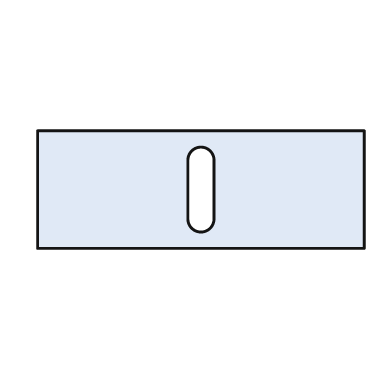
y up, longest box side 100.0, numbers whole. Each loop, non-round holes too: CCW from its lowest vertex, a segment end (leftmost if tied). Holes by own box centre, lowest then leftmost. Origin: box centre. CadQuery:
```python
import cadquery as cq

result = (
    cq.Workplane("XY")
    .moveTo(-50.0, -18.0)
    .lineTo(50.0, -18.0)
    .lineTo(50.0, 18.0)
    .lineTo(-50.0, 18.0)
    .close()
    .moveTo(-4.0, -9.0)
    .threePointArc((0.0, -13.0), (4.0, -9.0))
    .lineTo(4.0, 9.0)
    .threePointArc((0.0, 13.0), (-4.0, 9.0))
    .close()
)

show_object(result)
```